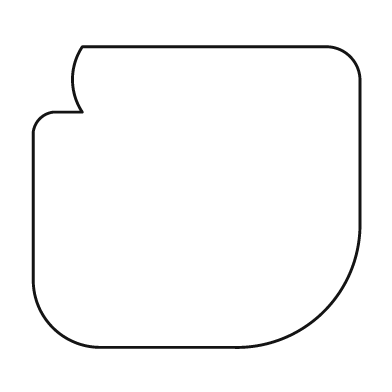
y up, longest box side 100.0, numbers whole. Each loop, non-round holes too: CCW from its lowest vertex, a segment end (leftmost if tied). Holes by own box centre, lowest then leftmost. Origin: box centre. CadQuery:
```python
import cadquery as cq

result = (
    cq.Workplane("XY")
    .moveTo(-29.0, -46.0)
    .lineTo(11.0, -46.0)
    .threePointArc((39.0, -35.0), (50.0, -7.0))
    .lineTo(50.0, 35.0)
    .threePointArc((47.0, 43.0), (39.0, 46.0))
    .lineTo(-35.0, 46.0)
    .threePointArc((-38.0, 36.0), (-35.0, 26.0))
    .lineTo(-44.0, 26.0)
    .threePointArc((-48.0, 24.0), (-50.0, 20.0))
    .lineTo(-50.0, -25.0)
    .threePointArc((-44.0, -40.0), (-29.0, -46.0))
    .close()
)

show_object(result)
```